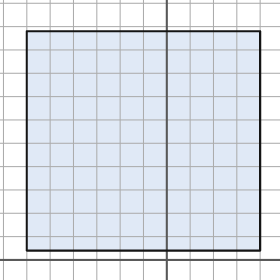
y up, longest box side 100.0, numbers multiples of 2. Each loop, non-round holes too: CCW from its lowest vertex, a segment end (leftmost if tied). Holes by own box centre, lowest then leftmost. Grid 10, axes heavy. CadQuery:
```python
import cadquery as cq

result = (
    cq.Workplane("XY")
    .moveTo(-60.0, 4.0)
    .lineTo(40.0, 4.0)
    .lineTo(40.0, 98.0)
    .lineTo(-60.0, 98.0)
    .close()
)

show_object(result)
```